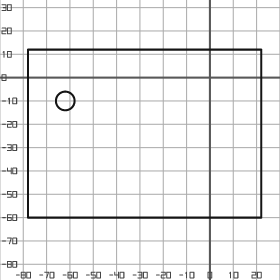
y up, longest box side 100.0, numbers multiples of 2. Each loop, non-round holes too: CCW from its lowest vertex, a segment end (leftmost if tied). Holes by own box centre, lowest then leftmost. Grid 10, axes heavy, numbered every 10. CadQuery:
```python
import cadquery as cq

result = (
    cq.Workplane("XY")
    .moveTo(-78.0, -60.0)
    .lineTo(22.0, -60.0)
    .lineTo(22.0, 12.0)
    .lineTo(-78.0, 12.0)
    .close()
    .moveTo(-62.0, -10.0)
    .circle(4.0)
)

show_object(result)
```